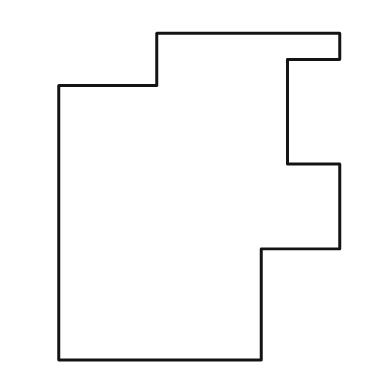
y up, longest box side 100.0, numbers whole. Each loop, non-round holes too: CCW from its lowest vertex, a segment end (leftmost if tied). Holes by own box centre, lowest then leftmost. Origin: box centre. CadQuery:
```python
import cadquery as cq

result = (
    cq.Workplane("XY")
    .moveTo(-43.0, -50.0)
    .lineTo(19.0, -50.0)
    .lineTo(19.0, -16.0)
    .lineTo(43.0, -16.0)
    .lineTo(43.0, 10.0)
    .lineTo(27.0, 10.0)
    .lineTo(27.0, 42.0)
    .lineTo(43.0, 42.0)
    .lineTo(43.0, 50.0)
    .lineTo(-13.0, 50.0)
    .lineTo(-13.0, 34.0)
    .lineTo(-43.0, 34.0)
    .close()
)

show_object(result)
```